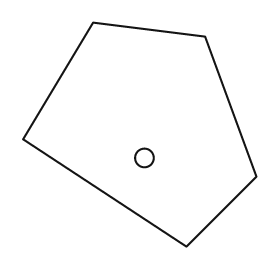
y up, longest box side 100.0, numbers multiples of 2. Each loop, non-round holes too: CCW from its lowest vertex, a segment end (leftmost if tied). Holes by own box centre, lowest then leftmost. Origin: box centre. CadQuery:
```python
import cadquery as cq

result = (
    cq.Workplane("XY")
    .moveTo(20.0, -48.0)
    .lineTo(50.0, -18.0)
    .lineTo(28.0, 42.0)
    .lineTo(-20.0, 48.0)
    .lineTo(-50.0, -2.0)
    .close()
    .moveTo(2.0, -10.0)
    .circle(4.0)
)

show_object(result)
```